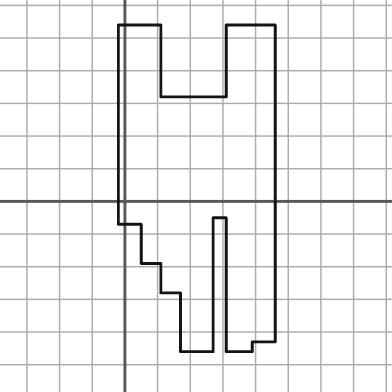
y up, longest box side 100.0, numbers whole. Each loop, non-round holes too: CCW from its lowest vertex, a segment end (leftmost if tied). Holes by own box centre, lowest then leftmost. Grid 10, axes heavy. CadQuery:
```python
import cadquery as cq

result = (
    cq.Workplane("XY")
    .moveTo(17.0, -46.0)
    .lineTo(27.0, -46.0)
    .lineTo(27.0, -5.0)
    .lineTo(31.0, -5.0)
    .lineTo(31.0, -46.0)
    .lineTo(39.0, -46.0)
    .lineTo(39.0, -43.0)
    .lineTo(46.0, -43.0)
    .lineTo(46.0, 54.0)
    .lineTo(31.0, 54.0)
    .lineTo(31.0, 32.0)
    .lineTo(11.0, 32.0)
    .lineTo(11.0, 54.0)
    .lineTo(-2.0, 54.0)
    .lineTo(-2.0, -7.0)
    .lineTo(5.0, -7.0)
    .lineTo(5.0, -19.0)
    .lineTo(11.0, -19.0)
    .lineTo(11.0, -28.0)
    .lineTo(17.0, -28.0)
    .close()
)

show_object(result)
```